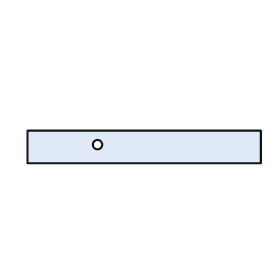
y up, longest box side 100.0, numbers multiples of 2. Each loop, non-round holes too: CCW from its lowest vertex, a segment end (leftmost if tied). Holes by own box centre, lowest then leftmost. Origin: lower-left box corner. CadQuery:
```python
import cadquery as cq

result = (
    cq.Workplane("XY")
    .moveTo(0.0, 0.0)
    .lineTo(100.0, 0.0)
    .lineTo(100.0, 14.0)
    .lineTo(0.0, 14.0)
    .close()
    .moveTo(30.0, 8.0)
    .circle(2.0)
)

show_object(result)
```